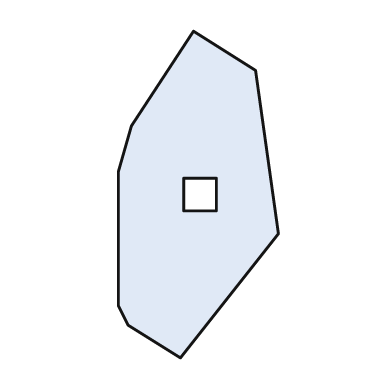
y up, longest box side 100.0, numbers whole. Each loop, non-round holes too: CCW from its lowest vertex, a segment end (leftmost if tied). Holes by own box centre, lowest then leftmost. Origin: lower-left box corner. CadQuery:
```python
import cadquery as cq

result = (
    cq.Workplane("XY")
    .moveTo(19.0, 0.0)
    .lineTo(49.0, 38.0)
    .lineTo(42.0, 88.0)
    .lineTo(23.0, 100.0)
    .lineTo(4.0, 71.0)
    .lineTo(0.0, 57.0)
    .lineTo(0.0, 16.0)
    .lineTo(3.0, 10.0)
    .close()
    .moveTo(20.0, 45.0)
    .lineTo(30.0, 45.0)
    .lineTo(30.0, 55.0)
    .lineTo(20.0, 55.0)
    .close()
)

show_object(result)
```